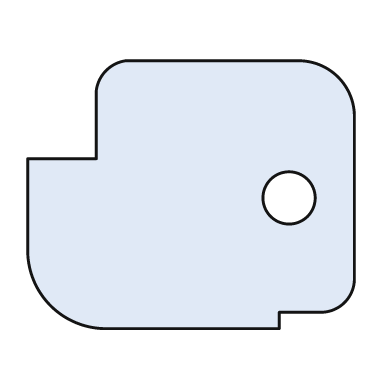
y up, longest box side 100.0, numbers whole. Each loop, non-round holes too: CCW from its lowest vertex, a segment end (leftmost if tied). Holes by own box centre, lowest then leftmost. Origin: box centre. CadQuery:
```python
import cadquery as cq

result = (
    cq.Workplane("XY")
    .moveTo(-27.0, -41.0)
    .lineTo(27.0, -41.0)
    .lineTo(27.0, -36.0)
    .lineTo(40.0, -36.0)
    .threePointArc((47.0, -33.0), (50.0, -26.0))
    .lineTo(50.0, 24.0)
    .threePointArc((45.0, 36.0), (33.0, 41.0))
    .lineTo(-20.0, 41.0)
    .threePointArc((-26.0, 38.0), (-29.0, 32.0))
    .lineTo(-29.0, 11.0)
    .lineTo(-50.0, 11.0)
    .lineTo(-50.0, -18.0)
    .threePointArc((-43.0, -34.0), (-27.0, -41.0))
    .close()
    .moveTo(30.0, -1.0)
    .circle(8.0)
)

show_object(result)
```